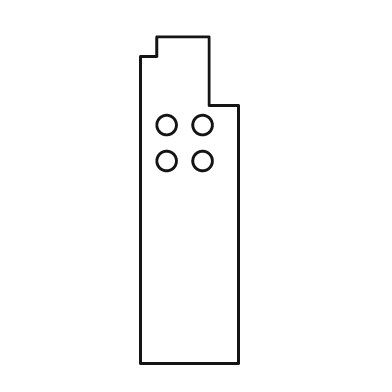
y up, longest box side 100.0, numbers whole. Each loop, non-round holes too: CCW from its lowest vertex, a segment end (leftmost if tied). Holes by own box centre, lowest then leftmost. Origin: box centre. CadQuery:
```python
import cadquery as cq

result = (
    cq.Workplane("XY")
    .moveTo(-15.0, -50.0)
    .lineTo(15.0, -50.0)
    .lineTo(15.0, 29.0)
    .lineTo(6.0, 29.0)
    .lineTo(6.0, 50.0)
    .lineTo(-10.0, 50.0)
    .lineTo(-10.0, 44.0)
    .lineTo(-15.0, 44.0)
    .close()
    .moveTo(-7.0, 12.0)
    .circle(3.0)
    .moveTo(4.0, 12.0)
    .circle(3.0)
    .moveTo(-7.0, 23.0)
    .circle(3.0)
    .moveTo(4.0, 23.0)
    .circle(3.0)
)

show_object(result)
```